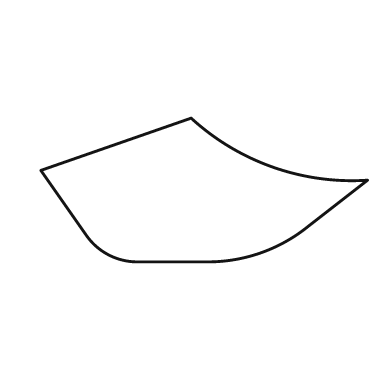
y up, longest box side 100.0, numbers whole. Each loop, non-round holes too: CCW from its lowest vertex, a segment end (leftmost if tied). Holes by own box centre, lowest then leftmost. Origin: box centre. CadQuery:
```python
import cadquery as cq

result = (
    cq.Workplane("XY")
    .moveTo(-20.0, -22.0)
    .lineTo(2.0, -22.0)
    .threePointArc((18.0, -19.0), (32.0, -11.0))
    .lineTo(50.0, 3.0)
    .threePointArc((21.0, 7.0), (-4.0, 22.0))
    .lineTo(-50.0, 6.0)
    .lineTo(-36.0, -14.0)
    .threePointArc((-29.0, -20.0), (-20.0, -22.0))
    .close()
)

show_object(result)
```